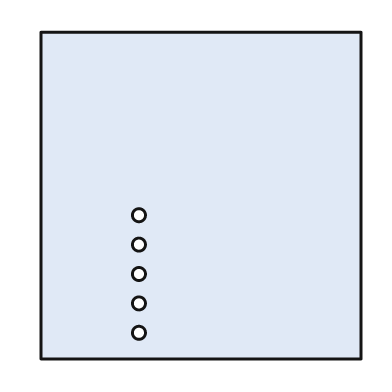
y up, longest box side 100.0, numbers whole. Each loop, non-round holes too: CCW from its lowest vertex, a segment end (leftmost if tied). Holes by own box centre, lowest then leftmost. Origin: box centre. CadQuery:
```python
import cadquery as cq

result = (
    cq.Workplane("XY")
    .moveTo(-49.0, -50.0)
    .lineTo(49.0, -50.0)
    .lineTo(49.0, 50.0)
    .lineTo(-49.0, 50.0)
    .close()
    .moveTo(-19.0, -42.0)
    .circle(2.0)
    .moveTo(-19.0, -33.0)
    .circle(2.0)
    .moveTo(-19.0, -24.0)
    .circle(2.0)
    .moveTo(-19.0, -15.0)
    .circle(2.0)
    .moveTo(-19.0, -6.0)
    .circle(2.0)
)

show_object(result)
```